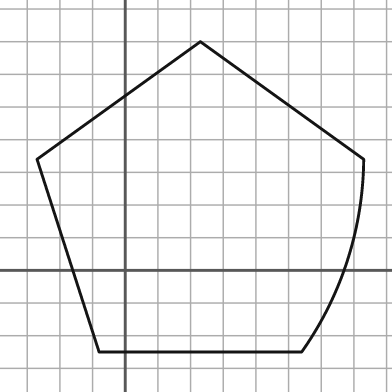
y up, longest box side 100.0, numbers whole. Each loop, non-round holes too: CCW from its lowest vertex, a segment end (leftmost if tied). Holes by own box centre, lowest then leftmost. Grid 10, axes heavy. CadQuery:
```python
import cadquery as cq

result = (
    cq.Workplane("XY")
    .moveTo(-8.0, -25.0)
    .lineTo(54.0, -25.0)
    .threePointArc((68.0, 3.0), (73.0, 34.0))
    .lineTo(23.0, 70.0)
    .lineTo(-27.0, 34.0)
    .close()
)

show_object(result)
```